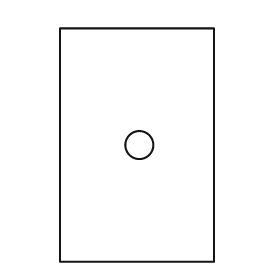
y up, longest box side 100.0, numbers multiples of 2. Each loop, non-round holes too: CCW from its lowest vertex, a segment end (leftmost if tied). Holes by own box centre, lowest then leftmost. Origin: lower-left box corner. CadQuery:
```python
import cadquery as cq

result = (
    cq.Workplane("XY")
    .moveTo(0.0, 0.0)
    .lineTo(66.0, 0.0)
    .lineTo(66.0, 100.0)
    .lineTo(0.0, 100.0)
    .close()
    .moveTo(34.0, 50.0)
    .circle(6.0)
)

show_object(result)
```